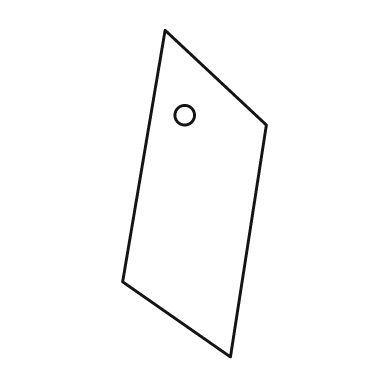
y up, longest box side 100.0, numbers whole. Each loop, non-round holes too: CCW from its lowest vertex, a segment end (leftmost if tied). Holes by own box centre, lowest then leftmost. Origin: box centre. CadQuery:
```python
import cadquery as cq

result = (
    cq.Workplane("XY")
    .moveTo(11.0, -50.0)
    .lineTo(22.0, 21.0)
    .lineTo(-9.0, 50.0)
    .lineTo(-22.0, -27.0)
    .close()
    .moveTo(-3.0, 24.0)
    .circle(3.0)
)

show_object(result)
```